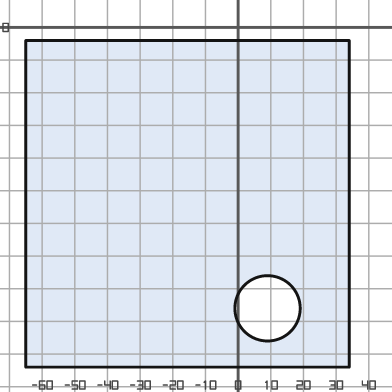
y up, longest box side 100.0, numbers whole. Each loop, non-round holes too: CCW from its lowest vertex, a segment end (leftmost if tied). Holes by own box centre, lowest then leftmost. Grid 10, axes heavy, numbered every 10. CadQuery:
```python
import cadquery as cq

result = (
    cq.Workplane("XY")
    .moveTo(-65.0, -104.0)
    .lineTo(34.0, -104.0)
    .lineTo(34.0, -4.0)
    .lineTo(-65.0, -4.0)
    .close()
    .moveTo(9.0, -86.0)
    .circle(10.0)
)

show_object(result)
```